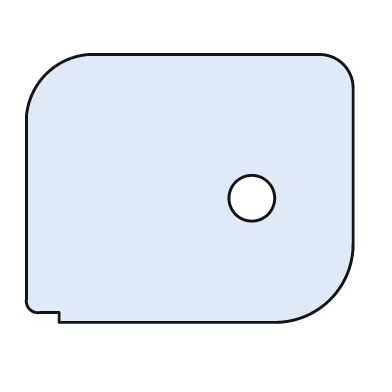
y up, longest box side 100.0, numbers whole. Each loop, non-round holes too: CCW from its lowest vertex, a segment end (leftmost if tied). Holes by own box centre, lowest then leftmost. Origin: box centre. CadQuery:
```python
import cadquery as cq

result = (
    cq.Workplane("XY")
    .moveTo(-40.0, -41.0)
    .lineTo(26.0, -41.0)
    .threePointArc((43.0, -34.0), (50.0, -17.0))
    .lineTo(50.0, 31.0)
    .threePointArc((47.0, 38.0), (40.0, 41.0))
    .lineTo(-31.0, 41.0)
    .threePointArc((-44.0, 35.0), (-50.0, 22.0))
    .lineTo(-50.0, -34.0)
    .threePointArc((-49.0, -37.0), (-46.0, -38.0))
    .lineTo(-40.0, -38.0)
    .close()
    .moveTo(19.0, -3.0)
    .circle(7.0)
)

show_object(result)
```